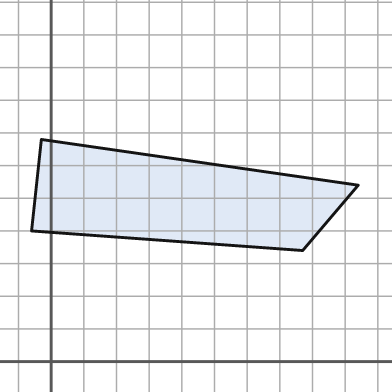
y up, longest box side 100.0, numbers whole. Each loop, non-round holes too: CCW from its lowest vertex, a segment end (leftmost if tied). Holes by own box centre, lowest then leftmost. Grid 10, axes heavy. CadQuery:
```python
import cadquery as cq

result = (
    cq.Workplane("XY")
    .moveTo(77.0, 34.0)
    .lineTo(94.0, 54.0)
    .lineTo(-3.0, 68.0)
    .lineTo(-6.0, 40.0)
    .close()
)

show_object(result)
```